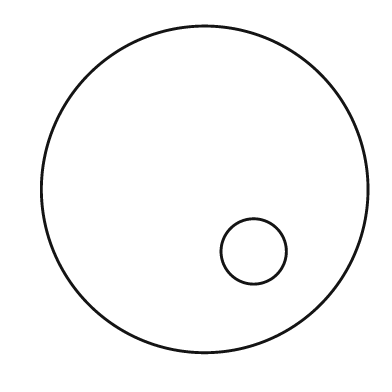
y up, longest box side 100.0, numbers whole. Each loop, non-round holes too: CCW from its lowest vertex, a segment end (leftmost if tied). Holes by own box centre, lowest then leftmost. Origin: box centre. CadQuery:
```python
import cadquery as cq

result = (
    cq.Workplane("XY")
    .moveTo(0.0, 0.0)
    .circle(50.0)
    .moveTo(15.0, -19.0)
    .circle(10.0)
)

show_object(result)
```